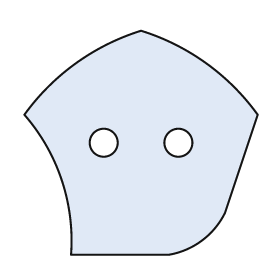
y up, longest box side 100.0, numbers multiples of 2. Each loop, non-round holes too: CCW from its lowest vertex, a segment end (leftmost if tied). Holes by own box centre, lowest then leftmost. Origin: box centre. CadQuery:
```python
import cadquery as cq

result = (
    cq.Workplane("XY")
    .moveTo(-30.0, -48.0)
    .lineTo(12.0, -48.0)
    .threePointArc((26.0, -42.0), (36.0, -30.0))
    .lineTo(50.0, 12.0)
    .threePointArc((28.0, 34.0), (0.0, 48.0))
    .threePointArc((-28.0, 34.0), (-50.0, 12.0))
    .threePointArc((-34.0, -16.0), (-30.0, -48.0))
    .close()
    .moveTo(-16.0, 0.0)
    .circle(6.0)
    .moveTo(16.0, 0.0)
    .circle(6.0)
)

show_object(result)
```